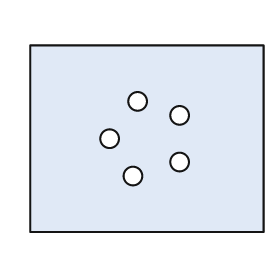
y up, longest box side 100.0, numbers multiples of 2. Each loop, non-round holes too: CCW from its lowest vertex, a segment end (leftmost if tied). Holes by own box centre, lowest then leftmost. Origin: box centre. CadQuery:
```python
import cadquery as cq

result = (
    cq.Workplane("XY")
    .moveTo(-50.0, -40.0)
    .lineTo(50.0, -40.0)
    .lineTo(50.0, 40.0)
    .lineTo(-50.0, 40.0)
    .close()
    .moveTo(-6.0, -16.0)
    .circle(4.0)
    .moveTo(14.0, -10.0)
    .circle(4.0)
    .moveTo(-16.0, 0.0)
    .circle(4.0)
    .moveTo(14.0, 10.0)
    .circle(4.0)
    .moveTo(-4.0, 16.0)
    .circle(4.0)
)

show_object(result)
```